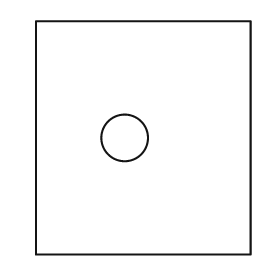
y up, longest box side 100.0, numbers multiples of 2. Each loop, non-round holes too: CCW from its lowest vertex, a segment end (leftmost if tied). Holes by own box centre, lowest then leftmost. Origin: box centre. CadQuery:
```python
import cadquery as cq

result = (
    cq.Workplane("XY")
    .moveTo(-46.0, -50.0)
    .lineTo(46.0, -50.0)
    .lineTo(46.0, 50.0)
    .lineTo(-46.0, 50.0)
    .close()
    .moveTo(-8.0, 0.0)
    .circle(10.0)
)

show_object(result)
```